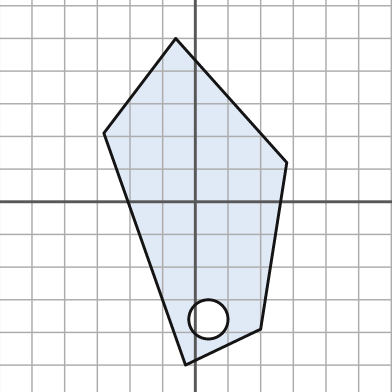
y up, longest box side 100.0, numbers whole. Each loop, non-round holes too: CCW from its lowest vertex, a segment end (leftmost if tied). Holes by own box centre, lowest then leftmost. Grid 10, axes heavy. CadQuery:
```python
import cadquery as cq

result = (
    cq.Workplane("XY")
    .moveTo(-3.0, -50.0)
    .lineTo(20.0, -39.0)
    .lineTo(28.0, 12.0)
    .lineTo(-6.0, 50.0)
    .lineTo(-28.0, 21.0)
    .close()
    .moveTo(4.0, -36.0)
    .circle(6.0)
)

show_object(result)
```